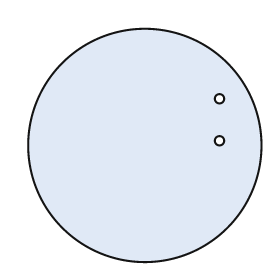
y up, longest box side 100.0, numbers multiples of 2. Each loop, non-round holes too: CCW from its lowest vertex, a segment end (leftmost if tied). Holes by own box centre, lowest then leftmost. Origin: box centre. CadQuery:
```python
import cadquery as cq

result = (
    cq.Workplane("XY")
    .moveTo(0.0, 0.0)
    .circle(50.0)
    .moveTo(32.0, 2.0)
    .circle(2.0)
    .moveTo(32.0, 20.0)
    .circle(2.0)
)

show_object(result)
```